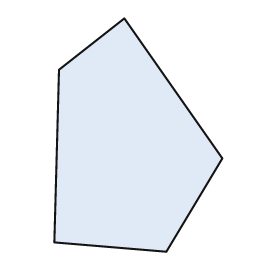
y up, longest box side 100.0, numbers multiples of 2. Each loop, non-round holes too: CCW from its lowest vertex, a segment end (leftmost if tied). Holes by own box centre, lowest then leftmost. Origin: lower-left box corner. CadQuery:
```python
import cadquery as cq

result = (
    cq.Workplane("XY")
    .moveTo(48.0, 0.0)
    .lineTo(72.0, 40.0)
    .lineTo(30.0, 100.0)
    .lineTo(2.0, 78.0)
    .lineTo(0.0, 4.0)
    .close()
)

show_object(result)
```